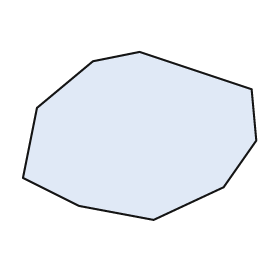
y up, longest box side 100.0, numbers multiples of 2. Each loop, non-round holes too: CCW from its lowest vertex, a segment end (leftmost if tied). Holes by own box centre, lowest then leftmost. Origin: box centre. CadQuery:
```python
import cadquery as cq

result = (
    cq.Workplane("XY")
    .moveTo(6.0, -36.0)
    .lineTo(36.0, -22.0)
    .lineTo(50.0, -2.0)
    .lineTo(48.0, 20.0)
    .lineTo(0.0, 36.0)
    .lineTo(-20.0, 32.0)
    .lineTo(-44.0, 12.0)
    .lineTo(-50.0, -18.0)
    .lineTo(-26.0, -30.0)
    .close()
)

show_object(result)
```